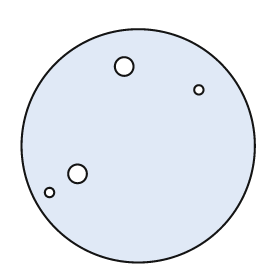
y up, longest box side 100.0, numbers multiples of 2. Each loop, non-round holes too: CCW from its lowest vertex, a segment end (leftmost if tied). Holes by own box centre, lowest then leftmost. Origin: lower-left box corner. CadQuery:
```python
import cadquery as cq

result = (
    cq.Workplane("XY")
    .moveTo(50.0, 50.0)
    .circle(50.0)
    .moveTo(12.0, 30.0)
    .circle(2.0)
    .moveTo(24.0, 38.0)
    .circle(4.0)
    .moveTo(76.0, 74.0)
    .circle(2.0)
    .moveTo(44.0, 84.0)
    .circle(4.0)
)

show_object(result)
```